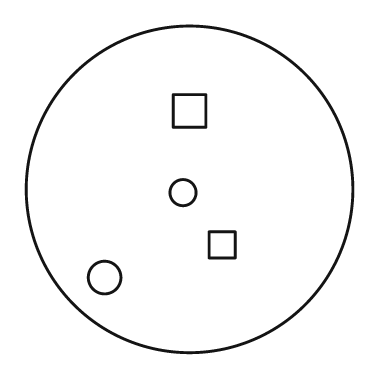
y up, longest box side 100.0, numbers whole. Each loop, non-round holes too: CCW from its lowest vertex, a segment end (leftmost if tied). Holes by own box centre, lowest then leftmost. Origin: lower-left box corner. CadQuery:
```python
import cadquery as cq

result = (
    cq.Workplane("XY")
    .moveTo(50.0, 50.0)
    .circle(50.0)
    .moveTo(24.0, 23.0)
    .circle(5.0)
    .moveTo(56.0, 29.0)
    .lineTo(64.0, 29.0)
    .lineTo(64.0, 37.0)
    .lineTo(56.0, 37.0)
    .close()
    .moveTo(48.0, 49.0)
    .circle(4.0)
    .moveTo(45.0, 69.0)
    .lineTo(55.0, 69.0)
    .lineTo(55.0, 79.0)
    .lineTo(45.0, 79.0)
    .close()
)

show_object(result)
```